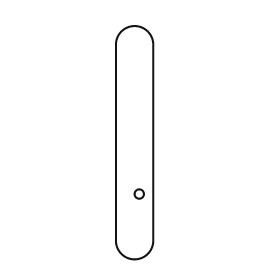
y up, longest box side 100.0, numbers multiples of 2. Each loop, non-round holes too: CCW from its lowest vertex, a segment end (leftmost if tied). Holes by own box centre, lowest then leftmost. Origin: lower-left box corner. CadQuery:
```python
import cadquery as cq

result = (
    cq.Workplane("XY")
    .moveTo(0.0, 8.0)
    .threePointArc((8.0, 0.0), (16.0, 8.0))
    .lineTo(16.0, 92.0)
    .threePointArc((8.0, 100.0), (0.0, 92.0))
    .close()
    .moveTo(10.0, 28.0)
    .circle(2.0)
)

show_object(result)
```